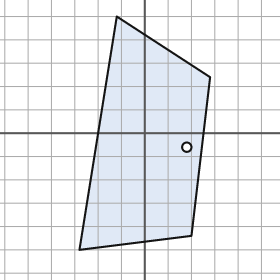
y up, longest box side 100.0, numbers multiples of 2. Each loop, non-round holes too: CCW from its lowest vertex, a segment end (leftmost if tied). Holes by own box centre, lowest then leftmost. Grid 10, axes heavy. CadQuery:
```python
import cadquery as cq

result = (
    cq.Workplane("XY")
    .moveTo(-28.0, -50.0)
    .lineTo(20.0, -44.0)
    .lineTo(28.0, 24.0)
    .lineTo(-12.0, 50.0)
    .close()
    .moveTo(18.0, -6.0)
    .circle(2.0)
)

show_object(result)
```